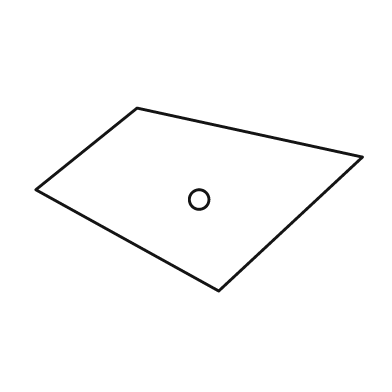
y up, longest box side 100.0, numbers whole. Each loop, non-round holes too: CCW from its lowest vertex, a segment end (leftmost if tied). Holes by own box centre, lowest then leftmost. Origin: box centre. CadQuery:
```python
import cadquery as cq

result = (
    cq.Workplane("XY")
    .moveTo(6.0, -28.0)
    .lineTo(50.0, 13.0)
    .lineTo(-19.0, 28.0)
    .lineTo(-50.0, 3.0)
    .close()
    .moveTo(0.0, 0.0)
    .circle(3.0)
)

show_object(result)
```